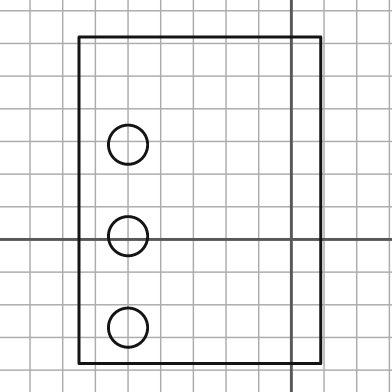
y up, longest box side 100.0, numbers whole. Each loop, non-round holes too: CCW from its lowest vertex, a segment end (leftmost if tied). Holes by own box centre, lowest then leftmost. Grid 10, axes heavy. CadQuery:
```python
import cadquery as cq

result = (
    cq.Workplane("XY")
    .moveTo(-65.0, -38.0)
    .lineTo(9.0, -38.0)
    .lineTo(9.0, 62.0)
    .lineTo(-65.0, 62.0)
    .close()
    .moveTo(-50.0, -27.0)
    .circle(6.0)
    .moveTo(-50.0, 1.0)
    .circle(6.0)
    .moveTo(-50.0, 29.0)
    .circle(6.0)
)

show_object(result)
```